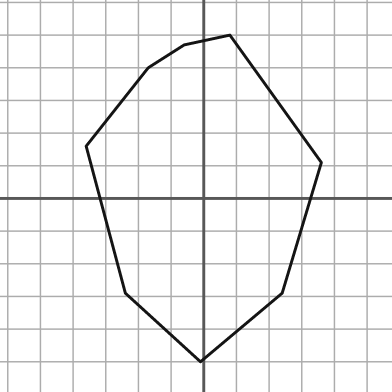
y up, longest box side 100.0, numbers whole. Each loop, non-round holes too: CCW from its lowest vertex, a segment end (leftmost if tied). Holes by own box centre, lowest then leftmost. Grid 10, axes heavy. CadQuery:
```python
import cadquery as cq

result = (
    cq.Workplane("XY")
    .moveTo(-1.0, -50.0)
    .lineTo(24.0, -29.0)
    .lineTo(36.0, 11.0)
    .lineTo(8.0, 50.0)
    .lineTo(-6.0, 47.0)
    .lineTo(-17.0, 40.0)
    .lineTo(-36.0, 16.0)
    .lineTo(-24.0, -29.0)
    .close()
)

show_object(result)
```